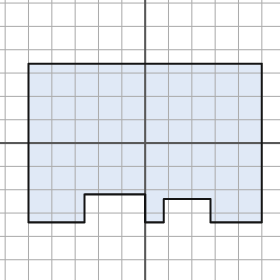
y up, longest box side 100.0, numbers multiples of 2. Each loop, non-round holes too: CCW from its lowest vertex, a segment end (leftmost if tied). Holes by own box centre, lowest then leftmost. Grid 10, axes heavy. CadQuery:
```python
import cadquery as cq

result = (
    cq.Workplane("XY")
    .moveTo(-50.0, -34.0)
    .lineTo(-26.0, -34.0)
    .lineTo(-26.0, -22.0)
    .lineTo(0.0, -22.0)
    .lineTo(0.0, -34.0)
    .lineTo(8.0, -34.0)
    .lineTo(8.0, -24.0)
    .lineTo(28.0, -24.0)
    .lineTo(28.0, -34.0)
    .lineTo(50.0, -34.0)
    .lineTo(50.0, 34.0)
    .lineTo(-50.0, 34.0)
    .close()
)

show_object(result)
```